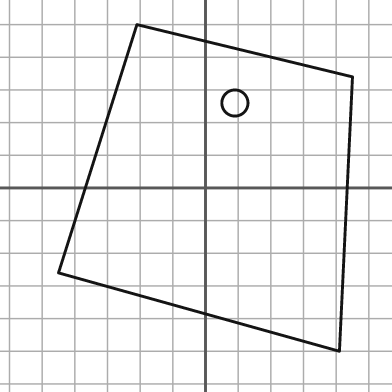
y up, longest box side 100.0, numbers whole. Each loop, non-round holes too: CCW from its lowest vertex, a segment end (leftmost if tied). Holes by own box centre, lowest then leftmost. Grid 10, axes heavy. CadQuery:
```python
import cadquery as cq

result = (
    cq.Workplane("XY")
    .moveTo(41.0, -50.0)
    .lineTo(45.0, 34.0)
    .lineTo(-21.0, 50.0)
    .lineTo(-45.0, -26.0)
    .close()
    .moveTo(9.0, 26.0)
    .circle(4.0)
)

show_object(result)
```